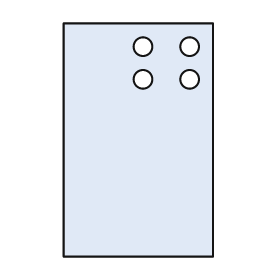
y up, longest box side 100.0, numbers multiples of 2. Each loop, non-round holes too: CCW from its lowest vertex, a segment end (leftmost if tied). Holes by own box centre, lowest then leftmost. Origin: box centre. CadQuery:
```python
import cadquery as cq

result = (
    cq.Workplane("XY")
    .moveTo(-32.0, -50.0)
    .lineTo(32.0, -50.0)
    .lineTo(32.0, 50.0)
    .lineTo(-32.0, 50.0)
    .close()
    .moveTo(2.0, 26.0)
    .circle(4.0)
    .moveTo(22.0, 26.0)
    .circle(4.0)
    .moveTo(2.0, 40.0)
    .circle(4.0)
    .moveTo(22.0, 40.0)
    .circle(4.0)
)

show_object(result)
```